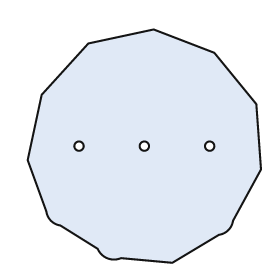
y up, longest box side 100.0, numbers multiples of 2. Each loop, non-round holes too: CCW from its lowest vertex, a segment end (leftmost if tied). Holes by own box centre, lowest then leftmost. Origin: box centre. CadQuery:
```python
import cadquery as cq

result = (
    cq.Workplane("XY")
    .moveTo(12.0, -50.0)
    .lineTo(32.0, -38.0)
    .threePointArc((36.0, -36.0), (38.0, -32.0))
    .lineTo(50.0, -10.0)
    .lineTo(48.0, 18.0)
    .lineTo(30.0, 40.0)
    .lineTo(4.0, 50.0)
    .lineTo(-24.0, 44.0)
    .lineTo(-44.0, 22.0)
    .lineTo(-50.0, -6.0)
    .lineTo(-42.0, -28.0)
    .threePointArc((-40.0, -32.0), (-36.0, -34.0))
    .lineTo(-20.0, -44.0)
    .threePointArc((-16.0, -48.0), (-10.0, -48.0))
    .close()
    .moveTo(-28.0, 0.0)
    .circle(2.0)
    .moveTo(0.0, 0.0)
    .circle(2.0)
    .moveTo(28.0, 0.0)
    .circle(2.0)
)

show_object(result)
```